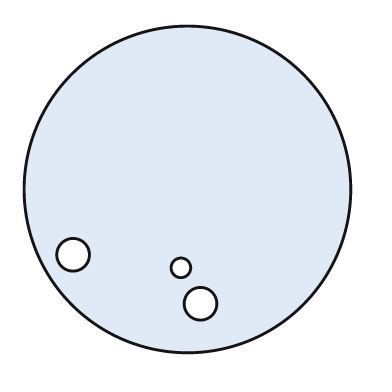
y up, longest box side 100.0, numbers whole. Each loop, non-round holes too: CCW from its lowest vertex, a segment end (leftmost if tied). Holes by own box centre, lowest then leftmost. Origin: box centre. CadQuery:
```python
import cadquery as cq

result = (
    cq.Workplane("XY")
    .moveTo(0.0, 0.0)
    .circle(50.0)
    .moveTo(4.0, -35.0)
    .circle(5.0)
    .moveTo(-2.0, -24.0)
    .circle(3.0)
    .moveTo(-35.0, -20.0)
    .circle(5.0)
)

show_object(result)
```